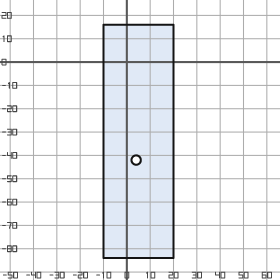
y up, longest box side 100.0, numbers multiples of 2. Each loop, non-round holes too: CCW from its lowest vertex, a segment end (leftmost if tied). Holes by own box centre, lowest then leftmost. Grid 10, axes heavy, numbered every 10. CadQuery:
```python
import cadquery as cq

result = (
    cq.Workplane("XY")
    .moveTo(-10.0, -84.0)
    .lineTo(20.0, -84.0)
    .lineTo(20.0, 16.0)
    .lineTo(-10.0, 16.0)
    .close()
    .moveTo(4.0, -42.0)
    .circle(2.0)
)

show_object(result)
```